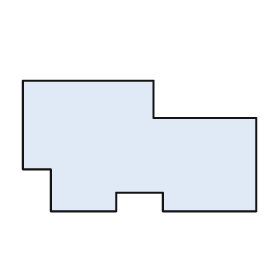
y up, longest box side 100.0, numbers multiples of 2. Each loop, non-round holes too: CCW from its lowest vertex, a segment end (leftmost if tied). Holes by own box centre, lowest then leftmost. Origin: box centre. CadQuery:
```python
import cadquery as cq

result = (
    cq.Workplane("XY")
    .moveTo(-38.0, -28.0)
    .lineTo(-10.0, -28.0)
    .lineTo(-10.0, -20.0)
    .lineTo(10.0, -20.0)
    .lineTo(10.0, -28.0)
    .lineTo(50.0, -28.0)
    .lineTo(50.0, 12.0)
    .lineTo(6.0, 12.0)
    .lineTo(6.0, 28.0)
    .lineTo(-50.0, 28.0)
    .lineTo(-50.0, -10.0)
    .lineTo(-38.0, -10.0)
    .close()
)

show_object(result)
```